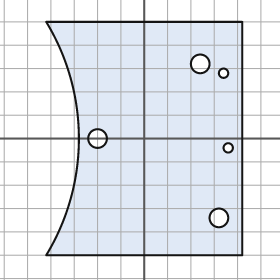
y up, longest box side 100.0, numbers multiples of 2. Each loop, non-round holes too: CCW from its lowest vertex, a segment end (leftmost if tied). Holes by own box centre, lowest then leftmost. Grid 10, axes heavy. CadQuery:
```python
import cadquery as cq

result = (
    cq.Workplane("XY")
    .moveTo(-42.0, -50.0)
    .lineTo(42.0, -50.0)
    .lineTo(42.0, 50.0)
    .lineTo(-42.0, 50.0)
    .threePointArc((-28.0, 0.0), (-42.0, -50.0))
    .close()
    .moveTo(32.0, -34.0)
    .circle(4.0)
    .moveTo(36.0, -4.0)
    .circle(2.0)
    .moveTo(-20.0, 0.0)
    .circle(4.0)
    .moveTo(34.0, 28.0)
    .circle(2.0)
    .moveTo(24.0, 32.0)
    .circle(4.0)
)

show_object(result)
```